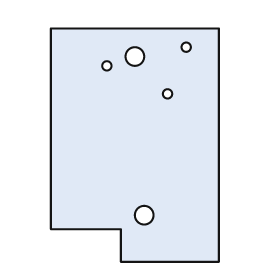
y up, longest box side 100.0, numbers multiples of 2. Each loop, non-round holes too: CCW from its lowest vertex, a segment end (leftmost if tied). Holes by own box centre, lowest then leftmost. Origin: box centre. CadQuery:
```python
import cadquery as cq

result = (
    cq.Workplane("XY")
    .moveTo(-6.0, -50.0)
    .lineTo(36.0, -50.0)
    .lineTo(36.0, 50.0)
    .lineTo(-36.0, 50.0)
    .lineTo(-36.0, -36.0)
    .lineTo(-6.0, -36.0)
    .close()
    .moveTo(4.0, -30.0)
    .circle(4.0)
    .moveTo(14.0, 22.0)
    .circle(2.0)
    .moveTo(-12.0, 34.0)
    .circle(2.0)
    .moveTo(0.0, 38.0)
    .circle(4.0)
    .moveTo(22.0, 42.0)
    .circle(2.0)
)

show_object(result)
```